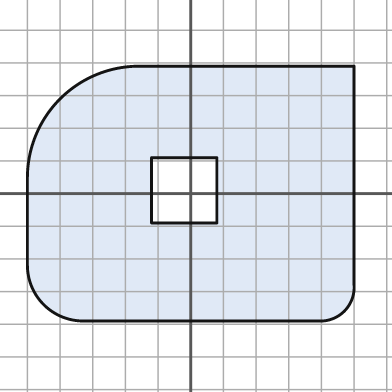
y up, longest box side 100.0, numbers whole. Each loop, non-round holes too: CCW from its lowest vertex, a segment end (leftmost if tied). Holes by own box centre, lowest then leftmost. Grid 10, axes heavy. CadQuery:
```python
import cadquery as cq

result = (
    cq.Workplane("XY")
    .moveTo(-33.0, -39.0)
    .lineTo(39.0, -39.0)
    .threePointArc((47.0, -36.0), (50.0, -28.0))
    .lineTo(50.0, 39.0)
    .lineTo(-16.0, 39.0)
    .threePointArc((-40.0, 29.0), (-50.0, 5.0))
    .lineTo(-50.0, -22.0)
    .threePointArc((-45.0, -34.0), (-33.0, -39.0))
    .close()
    .moveTo(-12.0, -9.0)
    .lineTo(8.0, -9.0)
    .lineTo(8.0, 11.0)
    .lineTo(-12.0, 11.0)
    .close()
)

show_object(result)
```